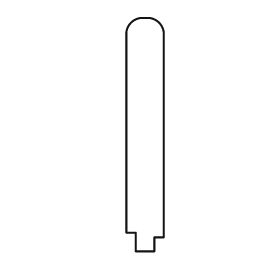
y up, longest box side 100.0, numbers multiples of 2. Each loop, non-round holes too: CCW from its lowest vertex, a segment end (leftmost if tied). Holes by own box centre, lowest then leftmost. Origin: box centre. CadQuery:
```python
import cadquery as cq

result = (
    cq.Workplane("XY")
    .moveTo(-4.0, -50.0)
    .lineTo(4.0, -50.0)
    .lineTo(4.0, -44.0)
    .lineTo(8.0, -44.0)
    .lineTo(8.0, 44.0)
    .threePointArc((6.0, 48.0), (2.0, 50.0))
    .lineTo(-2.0, 50.0)
    .threePointArc((-6.0, 48.0), (-8.0, 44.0))
    .lineTo(-8.0, -42.0)
    .lineTo(-4.0, -42.0)
    .close()
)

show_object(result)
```